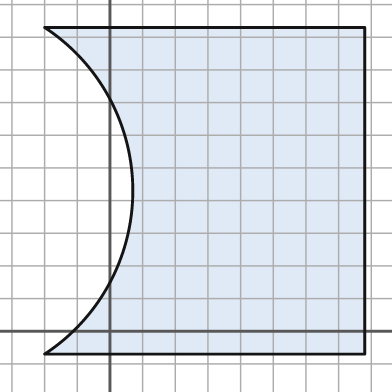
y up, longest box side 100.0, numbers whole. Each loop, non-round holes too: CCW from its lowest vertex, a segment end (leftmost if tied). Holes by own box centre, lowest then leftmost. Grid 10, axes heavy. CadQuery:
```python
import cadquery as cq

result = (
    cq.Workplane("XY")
    .moveTo(-20.0, -7.0)
    .lineTo(78.0, -7.0)
    .lineTo(78.0, 93.0)
    .lineTo(-20.0, 93.0)
    .threePointArc((7.0, 43.0), (-20.0, -7.0))
    .close()
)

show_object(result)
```